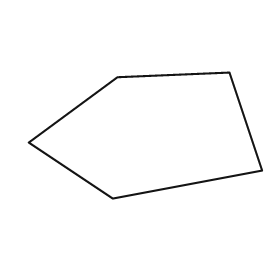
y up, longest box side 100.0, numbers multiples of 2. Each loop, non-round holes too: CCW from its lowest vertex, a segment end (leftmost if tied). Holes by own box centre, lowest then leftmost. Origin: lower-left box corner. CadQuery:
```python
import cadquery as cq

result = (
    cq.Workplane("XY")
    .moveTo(36.0, 0.0)
    .lineTo(100.0, 12.0)
    .lineTo(86.0, 54.0)
    .lineTo(38.0, 52.0)
    .lineTo(0.0, 24.0)
    .close()
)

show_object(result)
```